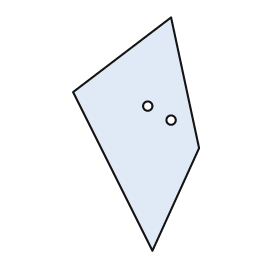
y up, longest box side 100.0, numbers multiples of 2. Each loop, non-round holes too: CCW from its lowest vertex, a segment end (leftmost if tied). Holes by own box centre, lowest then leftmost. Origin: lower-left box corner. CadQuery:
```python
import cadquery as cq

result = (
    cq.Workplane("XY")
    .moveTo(34.0, 0.0)
    .lineTo(54.0, 44.0)
    .lineTo(42.0, 100.0)
    .lineTo(0.0, 68.0)
    .close()
    .moveTo(42.0, 56.0)
    .circle(2.0)
    .moveTo(32.0, 62.0)
    .circle(2.0)
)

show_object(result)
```